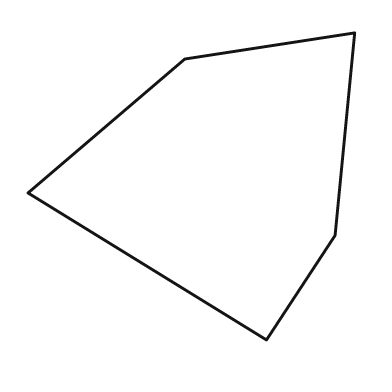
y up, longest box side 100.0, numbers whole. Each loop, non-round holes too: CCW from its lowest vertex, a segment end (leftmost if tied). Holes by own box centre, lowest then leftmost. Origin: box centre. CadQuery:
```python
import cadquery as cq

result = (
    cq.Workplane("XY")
    .moveTo(23.0, -47.0)
    .lineTo(44.0, -15.0)
    .lineTo(50.0, 47.0)
    .lineTo(-2.0, 39.0)
    .lineTo(-50.0, -2.0)
    .close()
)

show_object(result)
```